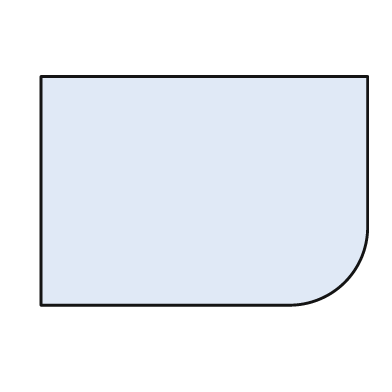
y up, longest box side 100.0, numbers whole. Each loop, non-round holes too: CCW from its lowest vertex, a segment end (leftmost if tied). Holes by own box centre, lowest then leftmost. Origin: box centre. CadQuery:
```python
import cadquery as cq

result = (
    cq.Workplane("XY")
    .moveTo(-50.0, -35.0)
    .lineTo(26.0, -35.0)
    .threePointArc((43.0, -28.0), (50.0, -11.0))
    .lineTo(50.0, 35.0)
    .lineTo(-50.0, 35.0)
    .close()
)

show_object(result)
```